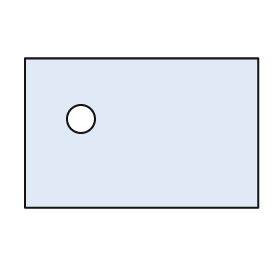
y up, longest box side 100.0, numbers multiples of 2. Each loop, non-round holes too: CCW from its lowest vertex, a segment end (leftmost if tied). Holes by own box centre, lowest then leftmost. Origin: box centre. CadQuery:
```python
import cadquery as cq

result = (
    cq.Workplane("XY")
    .moveTo(-50.0, -32.0)
    .lineTo(50.0, -32.0)
    .lineTo(50.0, 32.0)
    .lineTo(-50.0, 32.0)
    .close()
    .moveTo(-26.0, 6.0)
    .circle(6.0)
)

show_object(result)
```